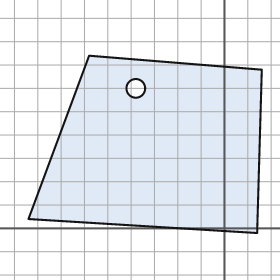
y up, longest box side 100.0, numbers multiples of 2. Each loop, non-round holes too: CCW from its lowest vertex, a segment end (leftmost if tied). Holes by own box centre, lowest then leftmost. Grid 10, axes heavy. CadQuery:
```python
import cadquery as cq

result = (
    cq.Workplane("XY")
    .moveTo(14.0, -2.0)
    .lineTo(16.0, 68.0)
    .lineTo(-58.0, 74.0)
    .lineTo(-84.0, 4.0)
    .close()
    .moveTo(-38.0, 60.0)
    .circle(4.0)
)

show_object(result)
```